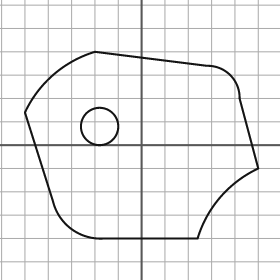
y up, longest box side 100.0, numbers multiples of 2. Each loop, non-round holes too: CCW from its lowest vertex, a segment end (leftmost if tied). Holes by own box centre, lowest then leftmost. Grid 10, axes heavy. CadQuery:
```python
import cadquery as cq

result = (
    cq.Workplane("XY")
    .moveTo(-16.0, -40.0)
    .lineTo(24.0, -40.0)
    .threePointArc((34.0, -22.0), (50.0, -10.0))
    .lineTo(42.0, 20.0)
    .threePointArc((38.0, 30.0), (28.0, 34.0))
    .lineTo(-20.0, 40.0)
    .threePointArc((-38.0, 30.0), (-50.0, 14.0))
    .lineTo(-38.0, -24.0)
    .threePointArc((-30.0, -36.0), (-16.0, -40.0))
    .close()
    .moveTo(-18.0, 8.0)
    .circle(8.0)
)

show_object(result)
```